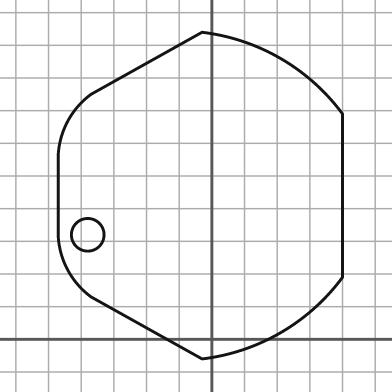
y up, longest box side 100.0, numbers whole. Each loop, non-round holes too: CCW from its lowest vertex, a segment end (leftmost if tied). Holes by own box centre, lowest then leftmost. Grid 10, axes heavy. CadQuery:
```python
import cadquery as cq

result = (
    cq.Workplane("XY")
    .moveTo(-3.0, -6.0)
    .threePointArc((21.0, 2.0), (40.0, 19.0))
    .lineTo(40.0, 69.0)
    .threePointArc((21.0, 86.0), (-3.0, 94.0))
    .lineTo(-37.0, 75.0)
    .threePointArc((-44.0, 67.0), (-47.0, 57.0))
    .lineTo(-47.0, 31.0)
    .threePointArc((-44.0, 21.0), (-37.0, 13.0))
    .close()
    .moveTo(-38.0, 32.0)
    .circle(5.0)
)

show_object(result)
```